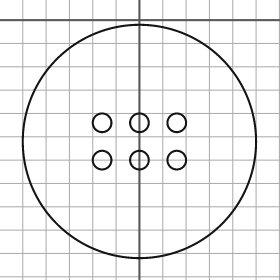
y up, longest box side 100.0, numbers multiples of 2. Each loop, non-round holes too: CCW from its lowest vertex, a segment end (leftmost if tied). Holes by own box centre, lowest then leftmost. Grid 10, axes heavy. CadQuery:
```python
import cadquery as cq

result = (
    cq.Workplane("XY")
    .moveTo(0.0, -52.0)
    .circle(50.0)
    .moveTo(-16.0, -60.0)
    .circle(4.0)
    .moveTo(0.0, -60.0)
    .circle(4.0)
    .moveTo(16.0, -60.0)
    .circle(4.0)
    .moveTo(-16.0, -44.0)
    .circle(4.0)
    .moveTo(0.0, -44.0)
    .circle(4.0)
    .moveTo(16.0, -44.0)
    .circle(4.0)
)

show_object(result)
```